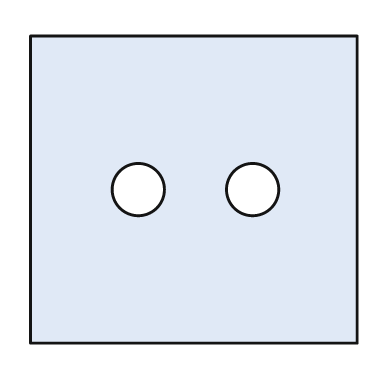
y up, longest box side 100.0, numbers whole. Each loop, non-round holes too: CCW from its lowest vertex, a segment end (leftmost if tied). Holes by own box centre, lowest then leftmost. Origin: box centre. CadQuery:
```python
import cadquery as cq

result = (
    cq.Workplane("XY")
    .moveTo(-50.0, -47.0)
    .lineTo(50.0, -47.0)
    .lineTo(50.0, 47.0)
    .lineTo(-50.0, 47.0)
    .close()
    .moveTo(-17.0, 0.0)
    .circle(8.0)
    .moveTo(18.0, 0.0)
    .circle(8.0)
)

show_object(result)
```